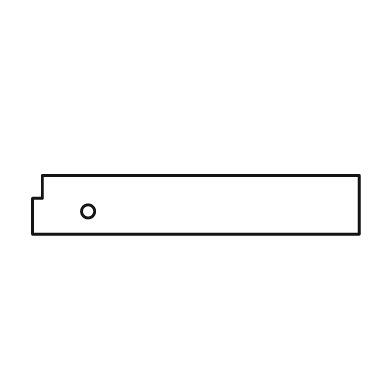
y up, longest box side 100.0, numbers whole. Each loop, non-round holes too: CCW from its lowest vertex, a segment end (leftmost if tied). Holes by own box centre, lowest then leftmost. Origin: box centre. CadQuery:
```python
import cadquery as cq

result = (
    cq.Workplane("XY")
    .moveTo(-50.0, -9.0)
    .lineTo(50.0, -9.0)
    .lineTo(50.0, 9.0)
    .lineTo(-47.0, 9.0)
    .lineTo(-47.0, 2.0)
    .lineTo(-50.0, 2.0)
    .close()
    .moveTo(-33.0, -2.0)
    .circle(2.0)
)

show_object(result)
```